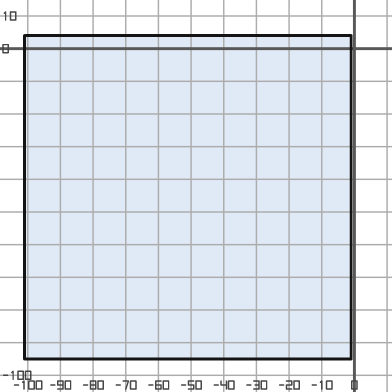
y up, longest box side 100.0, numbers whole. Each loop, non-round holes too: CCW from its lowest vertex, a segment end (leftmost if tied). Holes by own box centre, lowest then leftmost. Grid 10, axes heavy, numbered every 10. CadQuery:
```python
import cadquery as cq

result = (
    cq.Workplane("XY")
    .moveTo(-101.0, -95.0)
    .lineTo(-1.0, -95.0)
    .lineTo(-1.0, 4.0)
    .lineTo(-101.0, 4.0)
    .close()
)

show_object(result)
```